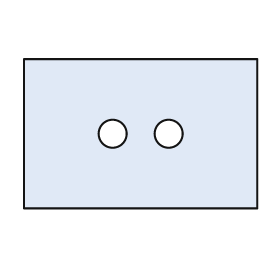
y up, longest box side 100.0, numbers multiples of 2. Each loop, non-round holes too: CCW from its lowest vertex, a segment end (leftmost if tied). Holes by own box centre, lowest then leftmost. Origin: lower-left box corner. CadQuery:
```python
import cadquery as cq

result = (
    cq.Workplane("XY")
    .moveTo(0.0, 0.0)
    .lineTo(100.0, 0.0)
    .lineTo(100.0, 64.0)
    .lineTo(0.0, 64.0)
    .close()
    .moveTo(38.0, 32.0)
    .circle(6.0)
    .moveTo(62.0, 32.0)
    .circle(6.0)
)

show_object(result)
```